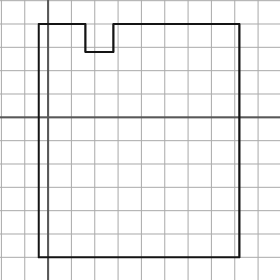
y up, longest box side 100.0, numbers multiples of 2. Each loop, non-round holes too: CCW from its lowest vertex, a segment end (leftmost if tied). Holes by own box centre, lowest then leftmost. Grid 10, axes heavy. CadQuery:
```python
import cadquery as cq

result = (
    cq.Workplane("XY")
    .moveTo(-4.0, -60.0)
    .lineTo(82.0, -60.0)
    .lineTo(82.0, 40.0)
    .lineTo(28.0, 40.0)
    .lineTo(28.0, 28.0)
    .lineTo(16.0, 28.0)
    .lineTo(16.0, 40.0)
    .lineTo(-4.0, 40.0)
    .close()
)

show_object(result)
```